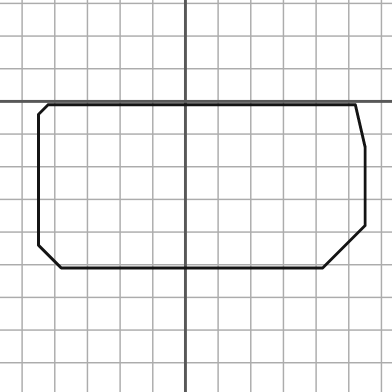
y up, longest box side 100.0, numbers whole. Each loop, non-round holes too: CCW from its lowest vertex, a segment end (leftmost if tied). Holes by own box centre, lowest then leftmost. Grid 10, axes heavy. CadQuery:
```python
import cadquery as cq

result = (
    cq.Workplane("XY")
    .moveTo(-38.0, -51.0)
    .lineTo(42.0, -51.0)
    .lineTo(55.0, -38.0)
    .lineTo(55.0, -14.0)
    .lineTo(52.0, -1.0)
    .lineTo(-42.0, -1.0)
    .lineTo(-45.0, -4.0)
    .lineTo(-45.0, -44.0)
    .close()
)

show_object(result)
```